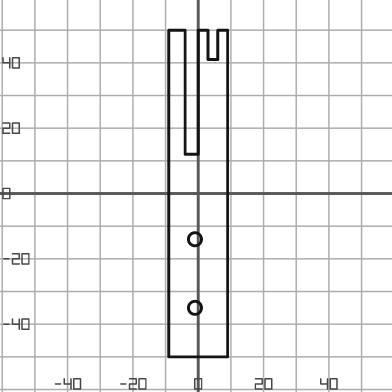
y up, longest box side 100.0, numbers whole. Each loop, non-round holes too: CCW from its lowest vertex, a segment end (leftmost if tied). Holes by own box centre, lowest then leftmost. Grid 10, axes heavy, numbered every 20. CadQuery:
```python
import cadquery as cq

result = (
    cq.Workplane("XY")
    .moveTo(-9.0, -50.0)
    .lineTo(9.0, -50.0)
    .lineTo(9.0, 50.0)
    .lineTo(6.0, 50.0)
    .lineTo(6.0, 41.0)
    .lineTo(3.0, 41.0)
    .lineTo(3.0, 50.0)
    .lineTo(0.0, 50.0)
    .lineTo(0.0, 12.0)
    .lineTo(-4.0, 12.0)
    .lineTo(-4.0, 50.0)
    .lineTo(-9.0, 50.0)
    .close()
    .moveTo(-1.0, -35.0)
    .circle(2.0)
    .moveTo(-1.0, -14.0)
    .circle(2.0)
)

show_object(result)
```